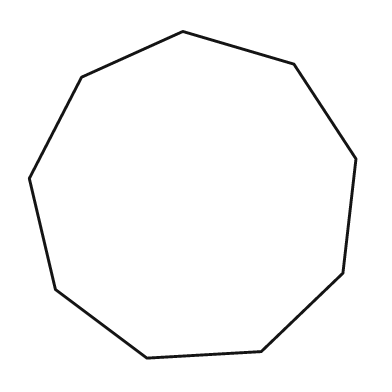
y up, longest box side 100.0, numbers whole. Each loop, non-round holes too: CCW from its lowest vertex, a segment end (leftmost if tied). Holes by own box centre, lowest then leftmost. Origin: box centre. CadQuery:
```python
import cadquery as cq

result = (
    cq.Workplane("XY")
    .moveTo(-14.0, -50.0)
    .lineTo(21.0, -48.0)
    .lineTo(46.0, -24.0)
    .lineTo(50.0, 11.0)
    .lineTo(31.0, 40.0)
    .lineTo(-3.0, 50.0)
    .lineTo(-34.0, 36.0)
    .lineTo(-50.0, 5.0)
    .lineTo(-42.0, -29.0)
    .close()
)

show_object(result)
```